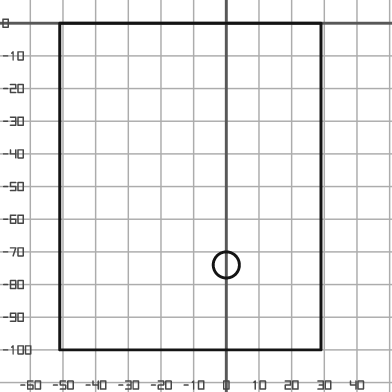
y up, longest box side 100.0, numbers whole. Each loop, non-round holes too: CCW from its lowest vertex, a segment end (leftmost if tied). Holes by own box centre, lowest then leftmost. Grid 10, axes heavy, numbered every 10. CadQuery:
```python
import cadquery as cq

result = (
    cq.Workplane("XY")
    .moveTo(-51.0, -100.0)
    .lineTo(29.0, -100.0)
    .lineTo(29.0, 0.0)
    .lineTo(-51.0, 0.0)
    .close()
    .moveTo(0.0, -74.0)
    .circle(4.0)
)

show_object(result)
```